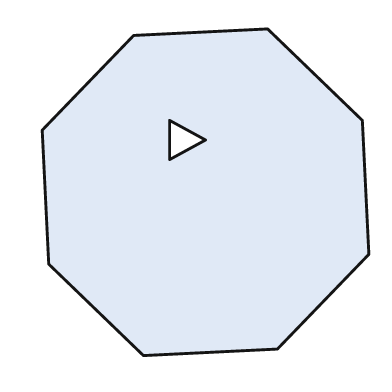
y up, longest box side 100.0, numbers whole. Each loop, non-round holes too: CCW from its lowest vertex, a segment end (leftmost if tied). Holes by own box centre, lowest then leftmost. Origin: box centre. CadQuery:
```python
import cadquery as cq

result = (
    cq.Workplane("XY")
    .moveTo(-19.0, -50.0)
    .lineTo(22.0, -48.0)
    .lineTo(50.0, -19.0)
    .lineTo(48.0, 22.0)
    .lineTo(19.0, 50.0)
    .lineTo(-22.0, 48.0)
    .lineTo(-50.0, 19.0)
    .lineTo(-48.0, -22.0)
    .close()
    .moveTo(-11.0, 10.0)
    .lineTo(0.0, 16.0)
    .lineTo(-11.0, 22.0)
    .close()
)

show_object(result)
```